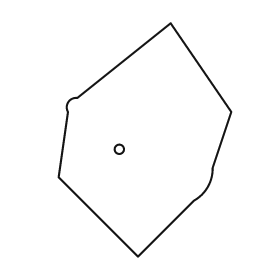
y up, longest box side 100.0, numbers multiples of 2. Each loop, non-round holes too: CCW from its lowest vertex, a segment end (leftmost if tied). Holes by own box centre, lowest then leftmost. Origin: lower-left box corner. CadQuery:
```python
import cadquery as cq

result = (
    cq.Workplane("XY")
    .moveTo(34.0, 0.0)
    .lineTo(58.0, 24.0)
    .threePointArc((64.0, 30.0), (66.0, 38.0))
    .lineTo(74.0, 62.0)
    .lineTo(48.0, 100.0)
    .lineTo(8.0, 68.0)
    .threePointArc((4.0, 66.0), (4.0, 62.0))
    .lineTo(0.0, 34.0)
    .close()
    .moveTo(26.0, 46.0)
    .circle(2.0)
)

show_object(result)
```